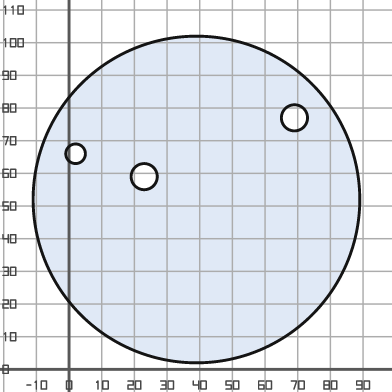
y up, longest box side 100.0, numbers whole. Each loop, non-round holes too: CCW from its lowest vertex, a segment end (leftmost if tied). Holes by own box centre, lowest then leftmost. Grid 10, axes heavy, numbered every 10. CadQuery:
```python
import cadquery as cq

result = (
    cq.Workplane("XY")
    .moveTo(39.0, 52.0)
    .circle(50.0)
    .moveTo(23.0, 59.0)
    .circle(4.0)
    .moveTo(2.0, 66.0)
    .circle(3.0)
    .moveTo(69.0, 77.0)
    .circle(4.0)
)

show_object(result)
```